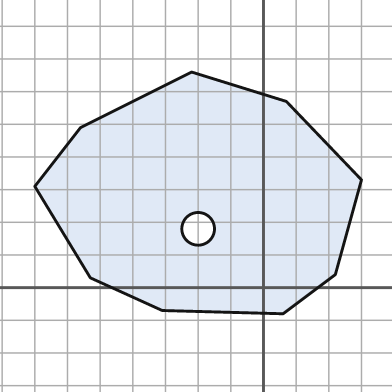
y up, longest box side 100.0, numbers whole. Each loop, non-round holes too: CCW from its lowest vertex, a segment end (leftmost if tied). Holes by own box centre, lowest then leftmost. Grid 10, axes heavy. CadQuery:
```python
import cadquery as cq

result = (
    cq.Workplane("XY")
    .moveTo(6.0, -8.0)
    .lineTo(22.0, 4.0)
    .lineTo(30.0, 33.0)
    .lineTo(7.0, 57.0)
    .lineTo(-22.0, 66.0)
    .lineTo(-56.0, 49.0)
    .lineTo(-70.0, 31.0)
    .lineTo(-53.0, 3.0)
    .lineTo(-31.0, -7.0)
    .close()
    .moveTo(-20.0, 18.0)
    .circle(5.0)
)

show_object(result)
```